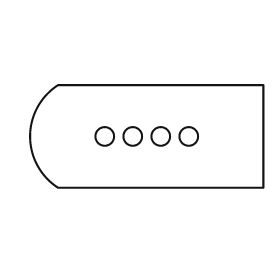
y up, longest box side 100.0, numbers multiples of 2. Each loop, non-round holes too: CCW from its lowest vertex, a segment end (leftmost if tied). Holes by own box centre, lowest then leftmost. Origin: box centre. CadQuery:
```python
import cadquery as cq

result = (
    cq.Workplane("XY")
    .moveTo(-38.0, -22.0)
    .lineTo(50.0, -22.0)
    .lineTo(50.0, 22.0)
    .lineTo(-38.0, 22.0)
    .threePointArc((-50.0, 0.0), (-38.0, -22.0))
    .close()
    .moveTo(-18.0, 0.0)
    .circle(4.0)
    .moveTo(-6.0, 0.0)
    .circle(4.0)
    .moveTo(6.0, 0.0)
    .circle(4.0)
    .moveTo(18.0, 0.0)
    .circle(4.0)
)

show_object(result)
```